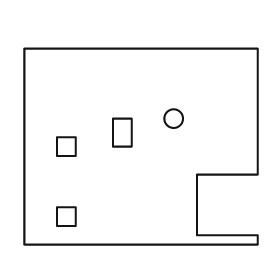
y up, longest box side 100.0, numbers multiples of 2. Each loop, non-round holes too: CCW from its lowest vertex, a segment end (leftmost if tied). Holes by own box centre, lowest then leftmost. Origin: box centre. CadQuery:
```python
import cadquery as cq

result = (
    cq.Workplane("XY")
    .moveTo(-50.0, -42.0)
    .lineTo(50.0, -42.0)
    .lineTo(50.0, -38.0)
    .lineTo(24.0, -38.0)
    .lineTo(24.0, -12.0)
    .lineTo(50.0, -12.0)
    .lineTo(50.0, 42.0)
    .lineTo(-50.0, 42.0)
    .close()
    .moveTo(-36.0, -34.0)
    .lineTo(-28.0, -34.0)
    .lineTo(-28.0, -26.0)
    .lineTo(-36.0, -26.0)
    .close()
    .moveTo(-36.0, -4.0)
    .lineTo(-28.0, -4.0)
    .lineTo(-28.0, 4.0)
    .lineTo(-36.0, 4.0)
    .close()
    .moveTo(-12.0, 0.0)
    .lineTo(-4.0, 0.0)
    .lineTo(-4.0, 12.0)
    .lineTo(-12.0, 12.0)
    .close()
    .moveTo(14.0, 12.0)
    .circle(4.0)
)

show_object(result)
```